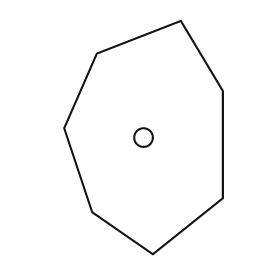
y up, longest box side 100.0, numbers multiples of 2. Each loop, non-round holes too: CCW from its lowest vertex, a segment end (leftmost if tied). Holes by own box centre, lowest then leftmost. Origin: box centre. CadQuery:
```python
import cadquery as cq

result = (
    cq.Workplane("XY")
    .moveTo(4.0, -50.0)
    .lineTo(34.0, -26.0)
    .lineTo(34.0, 20.0)
    .lineTo(16.0, 50.0)
    .lineTo(-20.0, 36.0)
    .lineTo(-34.0, 4.0)
    .lineTo(-22.0, -32.0)
    .close()
    .moveTo(0.0, 0.0)
    .circle(4.0)
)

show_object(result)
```